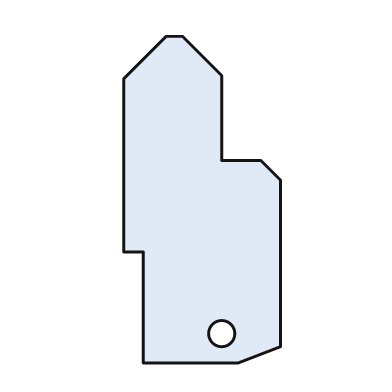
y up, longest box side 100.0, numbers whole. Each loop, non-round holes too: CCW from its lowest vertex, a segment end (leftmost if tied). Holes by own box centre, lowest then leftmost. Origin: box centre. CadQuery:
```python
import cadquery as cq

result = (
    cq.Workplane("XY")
    .moveTo(-18.0, -50.0)
    .lineTo(11.0, -50.0)
    .lineTo(24.0, -45.0)
    .lineTo(24.0, 6.0)
    .lineTo(18.0, 12.0)
    .lineTo(6.0, 12.0)
    .lineTo(6.0, 38.0)
    .lineTo(-6.0, 50.0)
    .lineTo(-11.0, 50.0)
    .lineTo(-24.0, 37.0)
    .lineTo(-24.0, -16.0)
    .lineTo(-18.0, -16.0)
    .close()
    .moveTo(6.0, -41.0)
    .circle(4.0)
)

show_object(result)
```